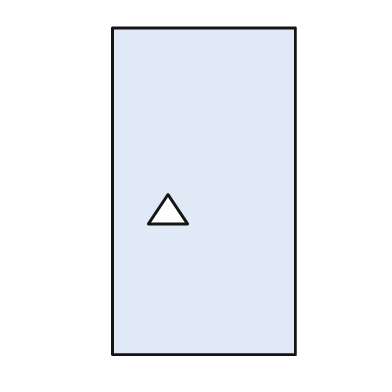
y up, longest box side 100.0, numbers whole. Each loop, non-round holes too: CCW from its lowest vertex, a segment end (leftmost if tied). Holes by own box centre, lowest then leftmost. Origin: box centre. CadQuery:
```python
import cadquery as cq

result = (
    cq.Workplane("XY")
    .moveTo(-28.0, -50.0)
    .lineTo(28.0, -50.0)
    .lineTo(28.0, 50.0)
    .lineTo(-28.0, 50.0)
    .close()
    .moveTo(-17.0, -10.0)
    .lineTo(-5.0, -10.0)
    .lineTo(-11.0, -1.0)
    .close()
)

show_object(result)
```